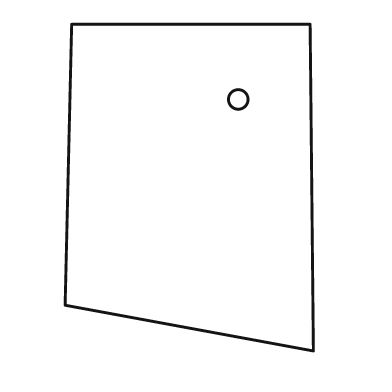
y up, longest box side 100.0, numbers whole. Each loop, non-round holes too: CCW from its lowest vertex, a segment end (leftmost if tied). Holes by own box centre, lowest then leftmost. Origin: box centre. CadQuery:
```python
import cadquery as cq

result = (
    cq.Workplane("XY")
    .moveTo(38.0, -50.0)
    .lineTo(37.0, 50.0)
    .lineTo(-36.0, 50.0)
    .lineTo(-38.0, -36.0)
    .close()
    .moveTo(15.0, 27.0)
    .circle(3.0)
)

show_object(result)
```